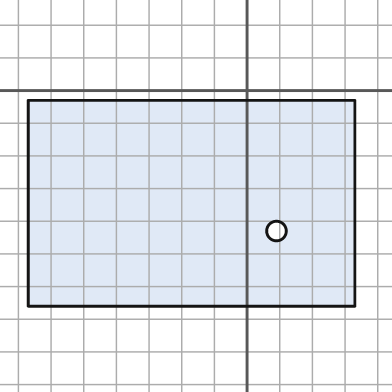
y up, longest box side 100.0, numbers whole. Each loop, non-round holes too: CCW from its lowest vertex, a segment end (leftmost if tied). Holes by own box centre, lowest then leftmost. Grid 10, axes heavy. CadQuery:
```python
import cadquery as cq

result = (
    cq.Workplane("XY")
    .moveTo(-67.0, -66.0)
    .lineTo(33.0, -66.0)
    .lineTo(33.0, -3.0)
    .lineTo(-67.0, -3.0)
    .close()
    .moveTo(9.0, -43.0)
    .circle(3.0)
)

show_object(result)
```